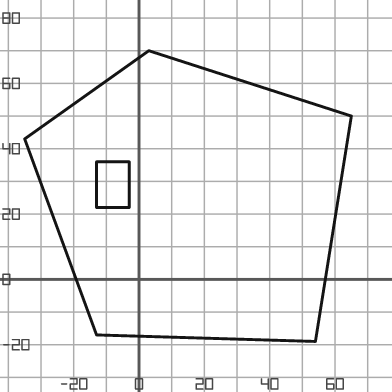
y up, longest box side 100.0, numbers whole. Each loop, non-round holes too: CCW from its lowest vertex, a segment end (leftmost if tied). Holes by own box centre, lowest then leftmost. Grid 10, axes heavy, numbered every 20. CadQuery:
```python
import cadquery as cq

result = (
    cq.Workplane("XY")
    .moveTo(54.0, -19.0)
    .lineTo(65.0, 50.0)
    .lineTo(3.0, 70.0)
    .lineTo(-35.0, 43.0)
    .lineTo(-13.0, -17.0)
    .close()
    .moveTo(-13.0, 22.0)
    .lineTo(-3.0, 22.0)
    .lineTo(-3.0, 36.0)
    .lineTo(-13.0, 36.0)
    .close()
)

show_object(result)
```